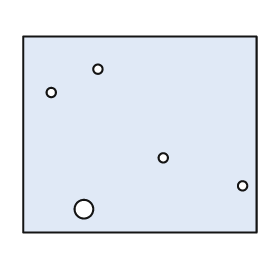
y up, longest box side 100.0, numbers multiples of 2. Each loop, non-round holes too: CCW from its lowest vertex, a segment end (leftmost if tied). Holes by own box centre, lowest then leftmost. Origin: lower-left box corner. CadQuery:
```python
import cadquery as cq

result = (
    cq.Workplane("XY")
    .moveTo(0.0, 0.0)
    .lineTo(100.0, 0.0)
    .lineTo(100.0, 84.0)
    .lineTo(0.0, 84.0)
    .close()
    .moveTo(26.0, 10.0)
    .circle(4.0)
    .moveTo(94.0, 20.0)
    .circle(2.0)
    .moveTo(60.0, 32.0)
    .circle(2.0)
    .moveTo(12.0, 60.0)
    .circle(2.0)
    .moveTo(32.0, 70.0)
    .circle(2.0)
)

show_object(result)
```